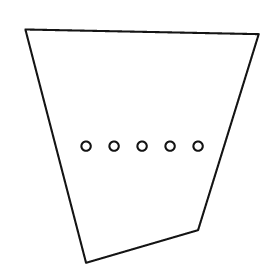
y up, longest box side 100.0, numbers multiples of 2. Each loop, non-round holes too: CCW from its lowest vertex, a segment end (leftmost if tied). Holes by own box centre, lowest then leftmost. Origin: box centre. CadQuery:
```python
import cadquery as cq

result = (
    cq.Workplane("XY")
    .moveTo(-24.0, -50.0)
    .lineTo(24.0, -36.0)
    .lineTo(50.0, 48.0)
    .lineTo(-50.0, 50.0)
    .close()
    .moveTo(-24.0, 0.0)
    .circle(2.0)
    .moveTo(-12.0, 0.0)
    .circle(2.0)
    .moveTo(0.0, 0.0)
    .circle(2.0)
    .moveTo(12.0, 0.0)
    .circle(2.0)
    .moveTo(24.0, 0.0)
    .circle(2.0)
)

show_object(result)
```